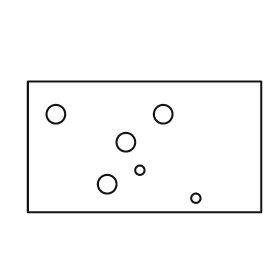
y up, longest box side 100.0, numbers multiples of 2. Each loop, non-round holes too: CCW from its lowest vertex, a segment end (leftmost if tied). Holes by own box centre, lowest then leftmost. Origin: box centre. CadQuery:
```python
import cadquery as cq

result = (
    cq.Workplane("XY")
    .moveTo(-50.0, -28.0)
    .lineTo(50.0, -28.0)
    .lineTo(50.0, 28.0)
    .lineTo(-50.0, 28.0)
    .close()
    .moveTo(22.0, -22.0)
    .circle(2.0)
    .moveTo(-16.0, -16.0)
    .circle(4.0)
    .moveTo(-2.0, -10.0)
    .circle(2.0)
    .moveTo(-8.0, 2.0)
    .circle(4.0)
    .moveTo(-38.0, 14.0)
    .circle(4.0)
    .moveTo(8.0, 14.0)
    .circle(4.0)
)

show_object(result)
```